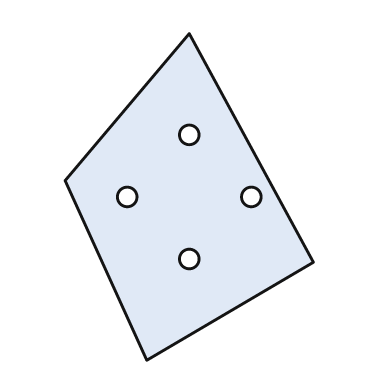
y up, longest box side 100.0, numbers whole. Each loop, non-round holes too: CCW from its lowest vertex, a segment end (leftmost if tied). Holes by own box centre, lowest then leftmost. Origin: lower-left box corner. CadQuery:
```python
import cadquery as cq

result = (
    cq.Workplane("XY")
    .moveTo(25.0, 0.0)
    .lineTo(76.0, 30.0)
    .lineTo(38.0, 100.0)
    .lineTo(0.0, 55.0)
    .close()
    .moveTo(38.0, 31.0)
    .circle(3.0)
    .moveTo(19.0, 50.0)
    .circle(3.0)
    .moveTo(57.0, 50.0)
    .circle(3.0)
    .moveTo(38.0, 69.0)
    .circle(3.0)
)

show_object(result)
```